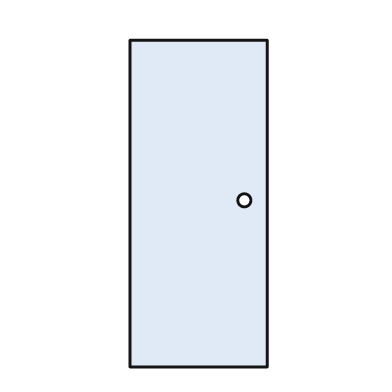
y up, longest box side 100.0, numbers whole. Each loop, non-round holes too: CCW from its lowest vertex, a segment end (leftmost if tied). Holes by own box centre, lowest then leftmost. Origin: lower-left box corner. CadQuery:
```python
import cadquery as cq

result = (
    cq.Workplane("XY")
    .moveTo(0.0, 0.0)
    .lineTo(42.0, 0.0)
    .lineTo(42.0, 100.0)
    .lineTo(0.0, 100.0)
    .close()
    .moveTo(35.0, 51.0)
    .circle(2.0)
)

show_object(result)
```